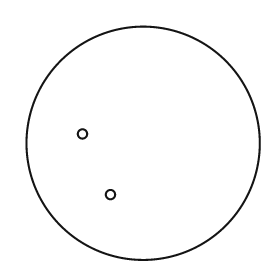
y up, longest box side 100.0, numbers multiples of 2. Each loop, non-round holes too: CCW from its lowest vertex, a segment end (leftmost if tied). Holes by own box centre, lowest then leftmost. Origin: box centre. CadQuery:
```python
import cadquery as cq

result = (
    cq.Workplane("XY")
    .moveTo(0.0, 0.0)
    .circle(50.0)
    .moveTo(-14.0, -22.0)
    .circle(2.0)
    .moveTo(-26.0, 4.0)
    .circle(2.0)
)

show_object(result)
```